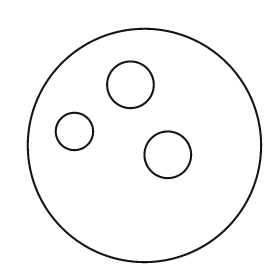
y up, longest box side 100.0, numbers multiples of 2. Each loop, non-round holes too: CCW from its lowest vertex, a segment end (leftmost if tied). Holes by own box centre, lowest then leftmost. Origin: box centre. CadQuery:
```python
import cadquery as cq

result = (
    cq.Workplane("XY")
    .moveTo(0.0, 0.0)
    .circle(50.0)
    .moveTo(10.0, -4.0)
    .circle(10.0)
    .moveTo(-30.0, 6.0)
    .circle(8.0)
    .moveTo(-6.0, 26.0)
    .circle(10.0)
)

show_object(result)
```